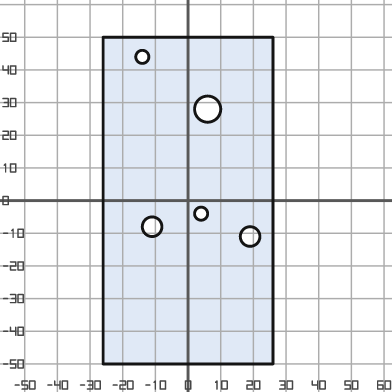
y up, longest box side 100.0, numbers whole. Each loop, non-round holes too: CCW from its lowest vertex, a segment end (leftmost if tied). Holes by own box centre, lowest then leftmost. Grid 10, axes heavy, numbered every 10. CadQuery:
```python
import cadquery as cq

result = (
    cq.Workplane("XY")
    .moveTo(-26.0, -50.0)
    .lineTo(26.0, -50.0)
    .lineTo(26.0, 50.0)
    .lineTo(-26.0, 50.0)
    .close()
    .moveTo(19.0, -11.0)
    .circle(3.0)
    .moveTo(-11.0, -8.0)
    .circle(3.0)
    .moveTo(4.0, -4.0)
    .circle(2.0)
    .moveTo(6.0, 28.0)
    .circle(4.0)
    .moveTo(-14.0, 44.0)
    .circle(2.0)
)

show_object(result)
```